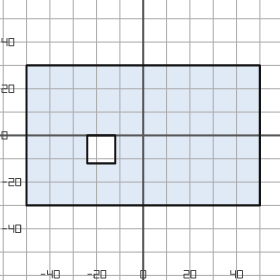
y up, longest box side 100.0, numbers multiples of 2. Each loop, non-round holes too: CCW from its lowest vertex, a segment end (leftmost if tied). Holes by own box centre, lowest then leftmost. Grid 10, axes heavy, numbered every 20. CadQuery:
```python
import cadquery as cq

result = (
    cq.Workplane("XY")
    .moveTo(-50.0, -30.0)
    .lineTo(50.0, -30.0)
    .lineTo(50.0, 30.0)
    .lineTo(-50.0, 30.0)
    .close()
    .moveTo(-24.0, -12.0)
    .lineTo(-12.0, -12.0)
    .lineTo(-12.0, 0.0)
    .lineTo(-24.0, 0.0)
    .close()
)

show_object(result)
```